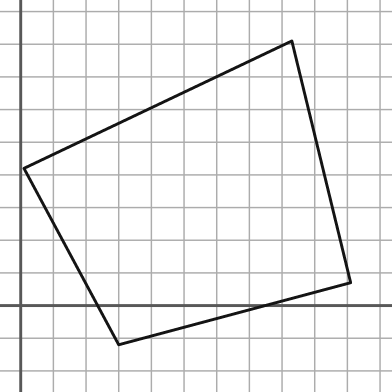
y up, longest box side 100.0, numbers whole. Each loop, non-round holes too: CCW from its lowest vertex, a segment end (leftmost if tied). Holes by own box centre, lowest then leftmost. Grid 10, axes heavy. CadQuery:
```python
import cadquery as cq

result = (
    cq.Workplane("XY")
    .moveTo(30.0, -12.0)
    .lineTo(101.0, 7.0)
    .lineTo(83.0, 81.0)
    .lineTo(1.0, 42.0)
    .close()
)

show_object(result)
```